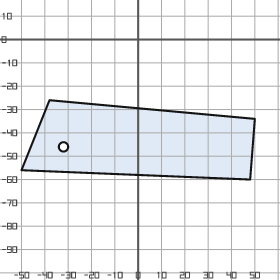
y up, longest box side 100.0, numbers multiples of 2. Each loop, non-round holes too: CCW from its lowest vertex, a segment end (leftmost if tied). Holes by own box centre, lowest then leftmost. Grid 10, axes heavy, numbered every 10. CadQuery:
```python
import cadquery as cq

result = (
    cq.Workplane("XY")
    .moveTo(48.0, -60.0)
    .lineTo(50.0, -34.0)
    .lineTo(-38.0, -26.0)
    .lineTo(-50.0, -56.0)
    .close()
    .moveTo(-32.0, -46.0)
    .circle(2.0)
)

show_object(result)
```